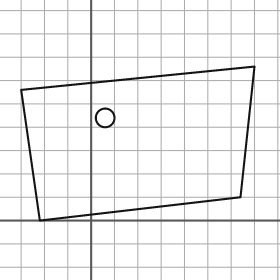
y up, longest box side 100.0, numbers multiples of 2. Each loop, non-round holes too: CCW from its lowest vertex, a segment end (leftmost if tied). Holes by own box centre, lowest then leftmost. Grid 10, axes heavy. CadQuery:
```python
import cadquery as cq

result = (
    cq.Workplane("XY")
    .moveTo(-22.0, 0.0)
    .lineTo(64.0, 10.0)
    .lineTo(70.0, 66.0)
    .lineTo(-30.0, 56.0)
    .close()
    .moveTo(6.0, 44.0)
    .circle(4.0)
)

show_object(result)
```